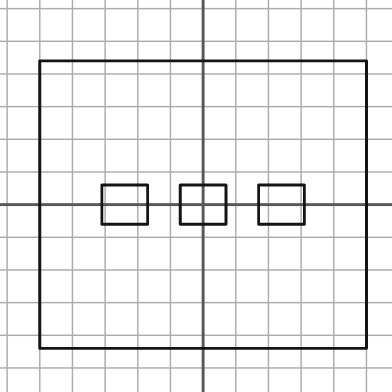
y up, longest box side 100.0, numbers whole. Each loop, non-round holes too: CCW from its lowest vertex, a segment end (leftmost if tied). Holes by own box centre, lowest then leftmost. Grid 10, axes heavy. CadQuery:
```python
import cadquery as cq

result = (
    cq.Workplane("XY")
    .moveTo(-50.0, -44.0)
    .lineTo(50.0, -44.0)
    .lineTo(50.0, 44.0)
    .lineTo(-50.0, 44.0)
    .close()
    .moveTo(-31.0, -6.0)
    .lineTo(-17.0, -6.0)
    .lineTo(-17.0, 6.0)
    .lineTo(-31.0, 6.0)
    .close()
    .moveTo(-7.0, -6.0)
    .lineTo(7.0, -6.0)
    .lineTo(7.0, 6.0)
    .lineTo(-7.0, 6.0)
    .close()
    .moveTo(17.0, -6.0)
    .lineTo(31.0, -6.0)
    .lineTo(31.0, 6.0)
    .lineTo(17.0, 6.0)
    .close()
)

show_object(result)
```